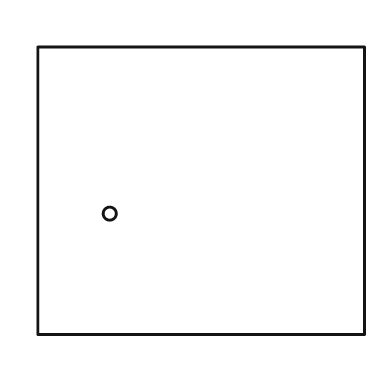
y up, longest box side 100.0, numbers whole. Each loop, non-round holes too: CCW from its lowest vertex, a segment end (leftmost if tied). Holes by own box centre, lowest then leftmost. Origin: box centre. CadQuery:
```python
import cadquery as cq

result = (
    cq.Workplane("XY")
    .moveTo(-50.0, -44.0)
    .lineTo(50.0, -44.0)
    .lineTo(50.0, 44.0)
    .lineTo(-50.0, 44.0)
    .close()
    .moveTo(-28.0, -7.0)
    .circle(2.0)
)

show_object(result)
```